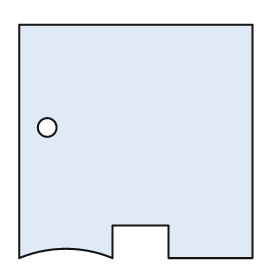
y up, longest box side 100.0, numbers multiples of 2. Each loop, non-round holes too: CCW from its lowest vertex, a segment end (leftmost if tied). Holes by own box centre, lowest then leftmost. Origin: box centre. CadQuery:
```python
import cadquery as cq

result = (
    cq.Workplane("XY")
    .moveTo(-50.0, -50.0)
    .threePointArc((-30.0, -46.0), (-10.0, -50.0))
    .lineTo(-10.0, -36.0)
    .lineTo(14.0, -36.0)
    .lineTo(14.0, -50.0)
    .lineTo(50.0, -50.0)
    .lineTo(50.0, 50.0)
    .lineTo(-50.0, 50.0)
    .close()
    .moveTo(-38.0, 6.0)
    .circle(4.0)
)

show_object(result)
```